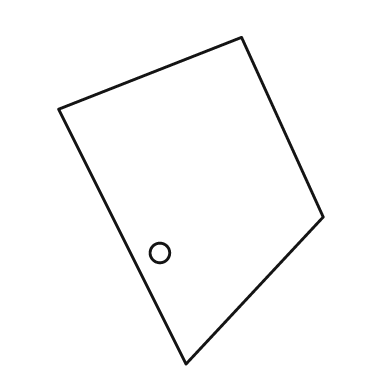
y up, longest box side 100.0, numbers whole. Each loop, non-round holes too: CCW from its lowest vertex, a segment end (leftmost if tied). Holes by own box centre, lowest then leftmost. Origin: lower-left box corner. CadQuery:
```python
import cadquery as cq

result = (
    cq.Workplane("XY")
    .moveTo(39.0, 0.0)
    .lineTo(81.0, 45.0)
    .lineTo(56.0, 100.0)
    .lineTo(0.0, 78.0)
    .close()
    .moveTo(31.0, 34.0)
    .circle(3.0)
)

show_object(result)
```